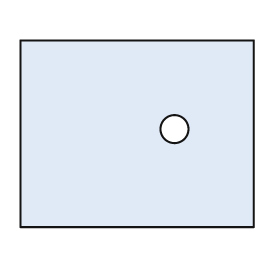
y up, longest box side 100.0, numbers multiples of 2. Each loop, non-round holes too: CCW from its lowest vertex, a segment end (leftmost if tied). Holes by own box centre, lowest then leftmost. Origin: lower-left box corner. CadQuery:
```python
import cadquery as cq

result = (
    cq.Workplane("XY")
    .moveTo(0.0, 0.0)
    .lineTo(100.0, 0.0)
    .lineTo(100.0, 80.0)
    .lineTo(0.0, 80.0)
    .close()
    .moveTo(66.0, 42.0)
    .circle(6.0)
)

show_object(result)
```